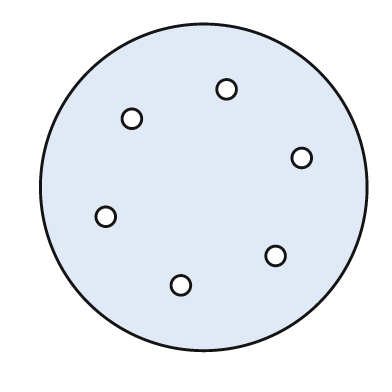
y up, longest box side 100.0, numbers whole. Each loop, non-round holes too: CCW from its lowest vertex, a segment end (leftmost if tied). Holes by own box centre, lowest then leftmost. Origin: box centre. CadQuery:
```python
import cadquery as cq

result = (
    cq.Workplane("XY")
    .moveTo(0.0, 0.0)
    .circle(50.0)
    .moveTo(-7.0, -30.0)
    .circle(3.0)
    .moveTo(22.0, -21.0)
    .circle(3.0)
    .moveTo(-30.0, -9.0)
    .circle(3.0)
    .moveTo(30.0, 9.0)
    .circle(3.0)
    .moveTo(-22.0, 21.0)
    .circle(3.0)
    .moveTo(7.0, 30.0)
    .circle(3.0)
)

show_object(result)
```